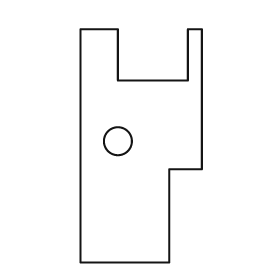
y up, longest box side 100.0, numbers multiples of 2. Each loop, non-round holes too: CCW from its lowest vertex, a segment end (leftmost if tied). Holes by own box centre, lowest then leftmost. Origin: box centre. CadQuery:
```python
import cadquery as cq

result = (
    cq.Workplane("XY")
    .moveTo(-26.0, -50.0)
    .lineTo(12.0, -50.0)
    .lineTo(12.0, -10.0)
    .lineTo(26.0, -10.0)
    .lineTo(26.0, 50.0)
    .lineTo(20.0, 50.0)
    .lineTo(20.0, 28.0)
    .lineTo(-10.0, 28.0)
    .lineTo(-10.0, 50.0)
    .lineTo(-26.0, 50.0)
    .close()
    .moveTo(-10.0, 2.0)
    .circle(6.0)
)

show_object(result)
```